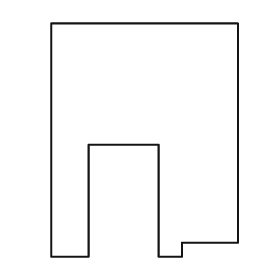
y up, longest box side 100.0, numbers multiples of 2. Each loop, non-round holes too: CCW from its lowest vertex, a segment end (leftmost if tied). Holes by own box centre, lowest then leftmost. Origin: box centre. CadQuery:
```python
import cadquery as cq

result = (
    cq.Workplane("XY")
    .moveTo(-40.0, -50.0)
    .lineTo(-24.0, -50.0)
    .lineTo(-24.0, -2.0)
    .lineTo(6.0, -2.0)
    .lineTo(6.0, -50.0)
    .lineTo(16.0, -50.0)
    .lineTo(16.0, -44.0)
    .lineTo(40.0, -44.0)
    .lineTo(40.0, 50.0)
    .lineTo(-40.0, 50.0)
    .close()
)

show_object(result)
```